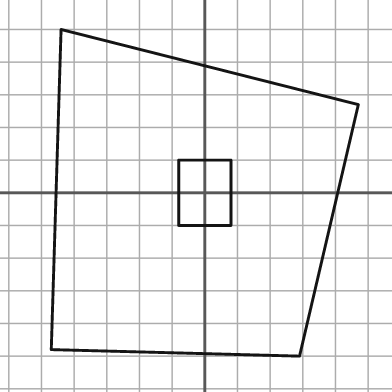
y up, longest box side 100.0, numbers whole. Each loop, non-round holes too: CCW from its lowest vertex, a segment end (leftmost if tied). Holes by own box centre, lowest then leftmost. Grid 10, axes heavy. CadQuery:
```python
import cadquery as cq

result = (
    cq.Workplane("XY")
    .moveTo(29.0, -50.0)
    .lineTo(47.0, 27.0)
    .lineTo(-44.0, 50.0)
    .lineTo(-47.0, -48.0)
    .close()
    .moveTo(-8.0, -10.0)
    .lineTo(8.0, -10.0)
    .lineTo(8.0, 10.0)
    .lineTo(-8.0, 10.0)
    .close()
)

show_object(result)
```